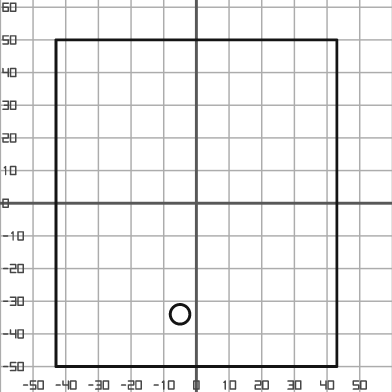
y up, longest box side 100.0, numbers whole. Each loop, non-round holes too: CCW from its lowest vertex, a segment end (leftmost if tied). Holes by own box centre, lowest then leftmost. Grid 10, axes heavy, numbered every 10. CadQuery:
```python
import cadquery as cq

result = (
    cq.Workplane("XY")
    .moveTo(-43.0, -50.0)
    .lineTo(43.0, -50.0)
    .lineTo(43.0, 50.0)
    .lineTo(-43.0, 50.0)
    .close()
    .moveTo(-5.0, -34.0)
    .circle(3.0)
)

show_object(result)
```